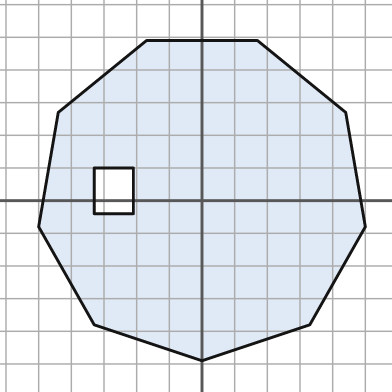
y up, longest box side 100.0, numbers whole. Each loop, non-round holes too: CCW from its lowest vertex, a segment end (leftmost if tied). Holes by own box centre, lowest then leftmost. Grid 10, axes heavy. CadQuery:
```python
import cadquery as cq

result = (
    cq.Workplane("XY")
    .moveTo(0.0, -49.0)
    .lineTo(33.0, -38.0)
    .lineTo(50.0, -8.0)
    .lineTo(44.0, 27.0)
    .lineTo(17.0, 49.0)
    .lineTo(-17.0, 49.0)
    .lineTo(-44.0, 27.0)
    .lineTo(-50.0, -8.0)
    .lineTo(-33.0, -38.0)
    .close()
    .moveTo(-33.0, -4.0)
    .lineTo(-21.0, -4.0)
    .lineTo(-21.0, 10.0)
    .lineTo(-33.0, 10.0)
    .close()
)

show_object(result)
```